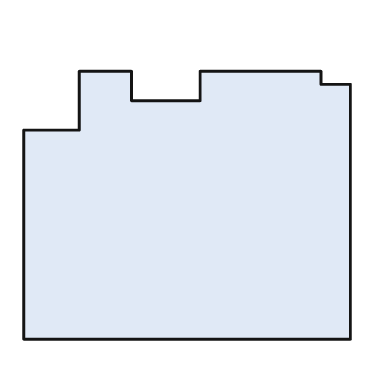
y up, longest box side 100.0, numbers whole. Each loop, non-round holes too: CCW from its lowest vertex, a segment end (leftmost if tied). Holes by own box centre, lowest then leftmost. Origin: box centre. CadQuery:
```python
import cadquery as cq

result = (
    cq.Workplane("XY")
    .moveTo(-50.0, -41.0)
    .lineTo(50.0, -41.0)
    .lineTo(50.0, 37.0)
    .lineTo(41.0, 37.0)
    .lineTo(41.0, 41.0)
    .lineTo(4.0, 41.0)
    .lineTo(4.0, 32.0)
    .lineTo(-17.0, 32.0)
    .lineTo(-17.0, 41.0)
    .lineTo(-33.0, 41.0)
    .lineTo(-33.0, 23.0)
    .lineTo(-50.0, 23.0)
    .close()
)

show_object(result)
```